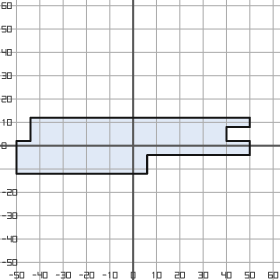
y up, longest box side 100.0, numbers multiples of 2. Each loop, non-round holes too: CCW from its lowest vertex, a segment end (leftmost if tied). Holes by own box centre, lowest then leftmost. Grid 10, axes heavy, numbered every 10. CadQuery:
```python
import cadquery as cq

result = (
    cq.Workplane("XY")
    .moveTo(-50.0, -12.0)
    .lineTo(6.0, -12.0)
    .lineTo(6.0, -4.0)
    .lineTo(50.0, -4.0)
    .lineTo(50.0, 2.0)
    .lineTo(40.0, 2.0)
    .lineTo(40.0, 8.0)
    .lineTo(50.0, 8.0)
    .lineTo(50.0, 12.0)
    .lineTo(-44.0, 12.0)
    .lineTo(-44.0, 2.0)
    .lineTo(-50.0, 2.0)
    .close()
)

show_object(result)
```